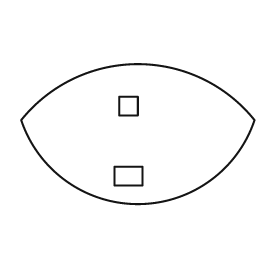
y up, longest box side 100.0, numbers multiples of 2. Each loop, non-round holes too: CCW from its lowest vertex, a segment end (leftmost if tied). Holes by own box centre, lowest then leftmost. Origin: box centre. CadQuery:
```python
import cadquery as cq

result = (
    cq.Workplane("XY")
    .moveTo(-50.0, 6.0)
    .threePointArc((0.0, -30.0), (50.0, 6.0))
    .threePointArc((0.0, 30.0), (-50.0, 6.0))
    .close()
    .moveTo(-10.0, -22.0)
    .lineTo(2.0, -22.0)
    .lineTo(2.0, -14.0)
    .lineTo(-10.0, -14.0)
    .close()
    .moveTo(-8.0, 8.0)
    .lineTo(0.0, 8.0)
    .lineTo(0.0, 16.0)
    .lineTo(-8.0, 16.0)
    .close()
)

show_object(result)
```